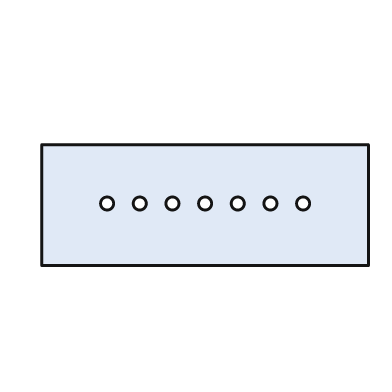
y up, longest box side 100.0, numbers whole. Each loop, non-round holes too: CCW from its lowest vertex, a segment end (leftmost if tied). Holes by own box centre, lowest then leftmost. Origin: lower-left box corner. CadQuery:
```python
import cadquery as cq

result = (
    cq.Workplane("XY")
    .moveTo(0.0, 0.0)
    .lineTo(100.0, 0.0)
    .lineTo(100.0, 37.0)
    .lineTo(0.0, 37.0)
    .close()
    .moveTo(20.0, 19.0)
    .circle(2.0)
    .moveTo(30.0, 19.0)
    .circle(2.0)
    .moveTo(40.0, 19.0)
    .circle(2.0)
    .moveTo(50.0, 19.0)
    .circle(2.0)
    .moveTo(60.0, 19.0)
    .circle(2.0)
    .moveTo(70.0, 19.0)
    .circle(2.0)
    .moveTo(80.0, 19.0)
    .circle(2.0)
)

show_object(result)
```